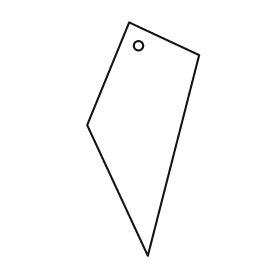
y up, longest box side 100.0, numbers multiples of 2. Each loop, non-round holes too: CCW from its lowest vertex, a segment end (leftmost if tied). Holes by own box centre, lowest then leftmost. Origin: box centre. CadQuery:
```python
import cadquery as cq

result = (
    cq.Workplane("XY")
    .moveTo(2.0, -50.0)
    .lineTo(24.0, 36.0)
    .lineTo(-6.0, 50.0)
    .lineTo(-24.0, 6.0)
    .close()
    .moveTo(-2.0, 40.0)
    .circle(2.0)
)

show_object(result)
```